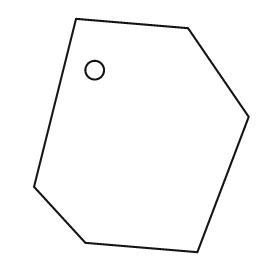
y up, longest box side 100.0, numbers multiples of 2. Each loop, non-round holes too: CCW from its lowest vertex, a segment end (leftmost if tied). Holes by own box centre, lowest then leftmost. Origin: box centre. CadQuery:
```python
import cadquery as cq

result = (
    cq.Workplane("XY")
    .moveTo(24.0, -50.0)
    .lineTo(46.0, 8.0)
    .lineTo(20.0, 46.0)
    .lineTo(-28.0, 50.0)
    .lineTo(-46.0, -22.0)
    .lineTo(-24.0, -46.0)
    .close()
    .moveTo(-20.0, 28.0)
    .circle(4.0)
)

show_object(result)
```